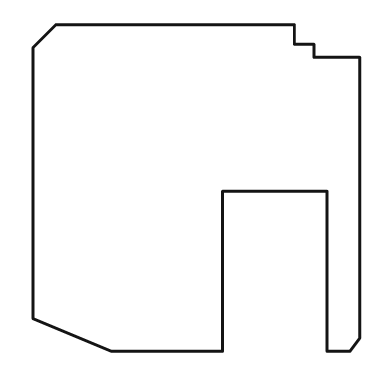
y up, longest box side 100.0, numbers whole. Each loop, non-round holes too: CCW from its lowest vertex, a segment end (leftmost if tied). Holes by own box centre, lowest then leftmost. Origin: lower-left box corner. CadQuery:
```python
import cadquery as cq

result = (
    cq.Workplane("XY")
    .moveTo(24.0, 0.0)
    .lineTo(58.0, 0.0)
    .lineTo(58.0, 49.0)
    .lineTo(90.0, 49.0)
    .lineTo(90.0, 0.0)
    .lineTo(97.0, 0.0)
    .lineTo(100.0, 4.0)
    .lineTo(100.0, 90.0)
    .lineTo(86.0, 90.0)
    .lineTo(86.0, 94.0)
    .lineTo(80.0, 94.0)
    .lineTo(80.0, 100.0)
    .lineTo(7.0, 100.0)
    .lineTo(0.0, 93.0)
    .lineTo(0.0, 10.0)
    .close()
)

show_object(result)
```